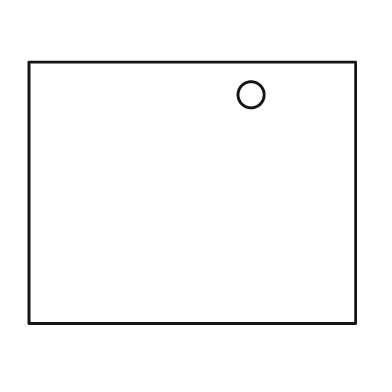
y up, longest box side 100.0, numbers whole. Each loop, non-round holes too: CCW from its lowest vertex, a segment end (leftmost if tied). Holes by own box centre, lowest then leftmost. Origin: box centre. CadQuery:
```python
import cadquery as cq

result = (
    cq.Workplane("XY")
    .moveTo(-50.0, -40.0)
    .lineTo(50.0, -40.0)
    .lineTo(50.0, 40.0)
    .lineTo(-50.0, 40.0)
    .close()
    .moveTo(18.0, 30.0)
    .circle(4.0)
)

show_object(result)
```